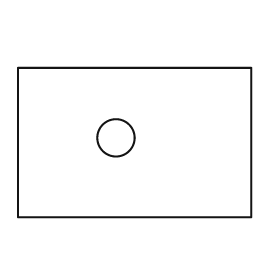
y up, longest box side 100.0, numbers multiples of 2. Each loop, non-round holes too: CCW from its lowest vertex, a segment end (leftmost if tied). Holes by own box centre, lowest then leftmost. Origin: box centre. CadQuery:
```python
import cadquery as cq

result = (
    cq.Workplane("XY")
    .moveTo(-50.0, -32.0)
    .lineTo(50.0, -32.0)
    .lineTo(50.0, 32.0)
    .lineTo(-50.0, 32.0)
    .close()
    .moveTo(-8.0, 2.0)
    .circle(8.0)
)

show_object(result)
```